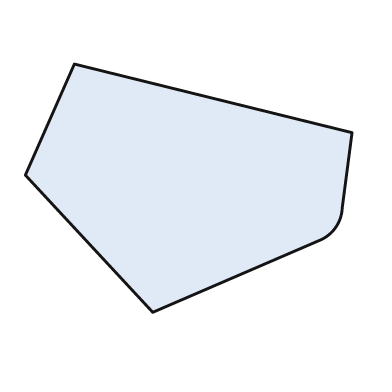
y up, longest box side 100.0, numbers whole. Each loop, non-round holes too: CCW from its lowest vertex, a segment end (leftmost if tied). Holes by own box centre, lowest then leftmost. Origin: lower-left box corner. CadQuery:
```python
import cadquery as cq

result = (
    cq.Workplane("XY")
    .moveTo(39.0, 0.0)
    .lineTo(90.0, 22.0)
    .threePointArc((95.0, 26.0), (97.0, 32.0))
    .lineTo(100.0, 55.0)
    .lineTo(15.0, 76.0)
    .lineTo(0.0, 42.0)
    .close()
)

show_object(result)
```